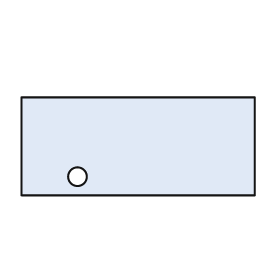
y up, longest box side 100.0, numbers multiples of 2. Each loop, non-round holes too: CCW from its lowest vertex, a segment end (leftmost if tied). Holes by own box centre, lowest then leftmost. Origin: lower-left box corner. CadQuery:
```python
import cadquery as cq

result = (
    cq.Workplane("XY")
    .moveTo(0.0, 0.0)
    .lineTo(100.0, 0.0)
    .lineTo(100.0, 42.0)
    .lineTo(0.0, 42.0)
    .close()
    .moveTo(24.0, 8.0)
    .circle(4.0)
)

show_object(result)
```